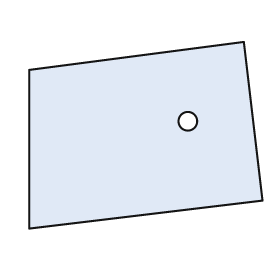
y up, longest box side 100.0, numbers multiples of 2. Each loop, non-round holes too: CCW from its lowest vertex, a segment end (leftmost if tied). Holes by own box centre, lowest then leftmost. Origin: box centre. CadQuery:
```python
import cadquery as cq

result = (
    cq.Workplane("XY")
    .moveTo(-50.0, -40.0)
    .lineTo(50.0, -28.0)
    .lineTo(42.0, 40.0)
    .lineTo(-50.0, 28.0)
    .close()
    .moveTo(18.0, 6.0)
    .circle(4.0)
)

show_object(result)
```